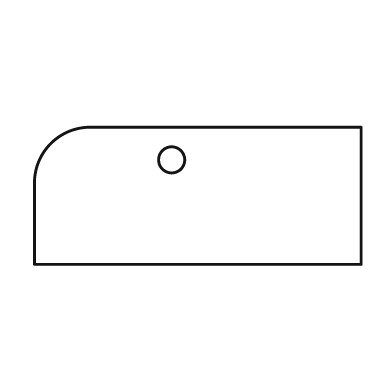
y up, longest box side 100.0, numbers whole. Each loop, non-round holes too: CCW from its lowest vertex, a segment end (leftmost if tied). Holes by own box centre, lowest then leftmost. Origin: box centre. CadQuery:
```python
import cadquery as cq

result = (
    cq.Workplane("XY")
    .moveTo(-50.0, -21.0)
    .lineTo(50.0, -21.0)
    .lineTo(50.0, 21.0)
    .lineTo(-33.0, 21.0)
    .threePointArc((-45.0, 16.0), (-50.0, 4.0))
    .close()
    .moveTo(-8.0, 11.0)
    .circle(4.0)
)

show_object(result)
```